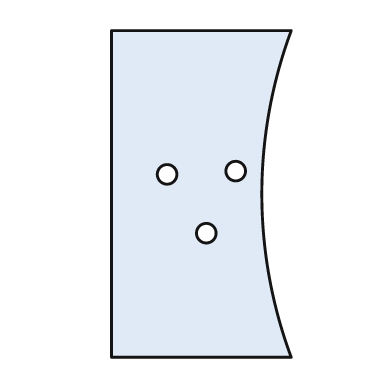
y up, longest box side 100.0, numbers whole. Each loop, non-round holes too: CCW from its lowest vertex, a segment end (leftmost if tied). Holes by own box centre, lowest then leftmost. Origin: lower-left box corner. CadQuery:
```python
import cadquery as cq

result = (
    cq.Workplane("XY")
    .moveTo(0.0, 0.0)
    .lineTo(55.0, 0.0)
    .threePointArc((46.0, 50.0), (55.0, 100.0))
    .lineTo(0.0, 100.0)
    .close()
    .moveTo(29.0, 38.0)
    .circle(3.0)
    .moveTo(17.0, 56.0)
    .circle(3.0)
    .moveTo(38.0, 57.0)
    .circle(3.0)
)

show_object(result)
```